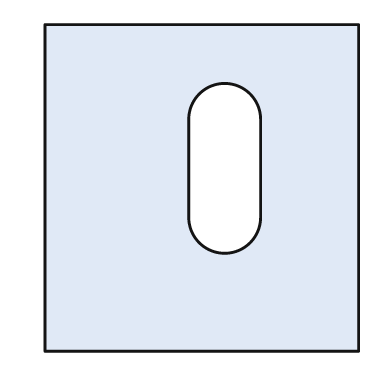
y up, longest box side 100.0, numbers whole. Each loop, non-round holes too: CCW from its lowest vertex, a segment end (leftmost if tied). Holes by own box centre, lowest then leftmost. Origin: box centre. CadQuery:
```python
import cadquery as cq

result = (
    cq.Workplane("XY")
    .moveTo(-48.0, -50.0)
    .lineTo(48.0, -50.0)
    .lineTo(48.0, 50.0)
    .lineTo(-48.0, 50.0)
    .close()
    .moveTo(-4.0, -9.0)
    .threePointArc((7.0, -20.0), (18.0, -9.0))
    .lineTo(18.0, 21.0)
    .threePointArc((7.0, 32.0), (-4.0, 21.0))
    .close()
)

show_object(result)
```